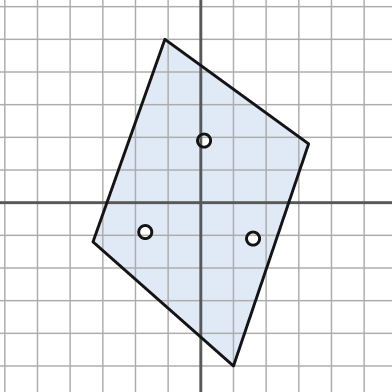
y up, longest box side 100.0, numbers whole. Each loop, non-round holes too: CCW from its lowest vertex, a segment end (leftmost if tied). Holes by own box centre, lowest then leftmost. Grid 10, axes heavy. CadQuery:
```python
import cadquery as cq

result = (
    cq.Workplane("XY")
    .moveTo(10.0, -50.0)
    .lineTo(33.0, 18.0)
    .lineTo(-11.0, 50.0)
    .lineTo(-33.0, -12.0)
    .close()
    .moveTo(16.0, -11.0)
    .circle(2.0)
    .moveTo(-17.0, -9.0)
    .circle(2.0)
    .moveTo(1.0, 19.0)
    .circle(2.0)
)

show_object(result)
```